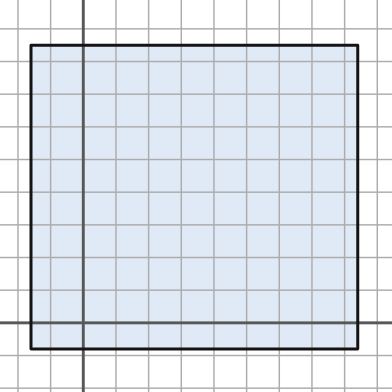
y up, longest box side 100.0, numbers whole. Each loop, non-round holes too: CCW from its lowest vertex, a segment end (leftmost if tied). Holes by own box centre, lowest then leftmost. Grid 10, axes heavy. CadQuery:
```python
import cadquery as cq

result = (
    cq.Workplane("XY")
    .moveTo(-16.0, -8.0)
    .lineTo(84.0, -8.0)
    .lineTo(84.0, 85.0)
    .lineTo(-16.0, 85.0)
    .close()
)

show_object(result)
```